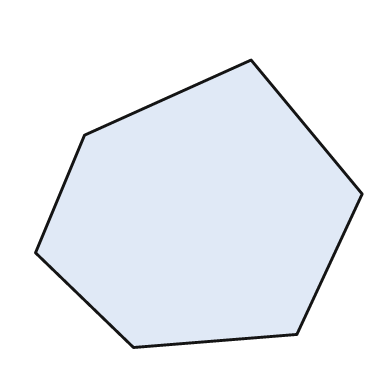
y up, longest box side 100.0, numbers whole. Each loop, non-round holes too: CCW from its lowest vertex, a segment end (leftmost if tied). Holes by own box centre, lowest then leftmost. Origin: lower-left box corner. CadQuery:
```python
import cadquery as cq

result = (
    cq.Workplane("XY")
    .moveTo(30.0, 0.0)
    .lineTo(80.0, 4.0)
    .lineTo(100.0, 47.0)
    .lineTo(66.0, 88.0)
    .lineTo(15.0, 65.0)
    .lineTo(0.0, 29.0)
    .close()
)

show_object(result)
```